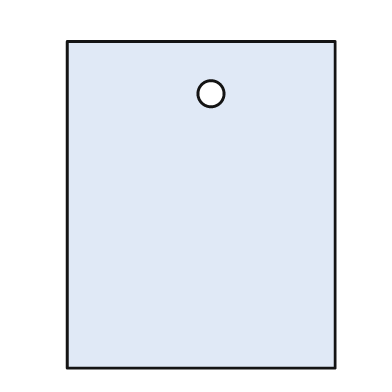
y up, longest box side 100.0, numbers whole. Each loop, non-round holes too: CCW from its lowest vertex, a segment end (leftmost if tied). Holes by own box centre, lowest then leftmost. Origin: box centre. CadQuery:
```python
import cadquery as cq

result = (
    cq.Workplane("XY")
    .moveTo(-41.0, -50.0)
    .lineTo(41.0, -50.0)
    .lineTo(41.0, 50.0)
    .lineTo(-41.0, 50.0)
    .close()
    .moveTo(3.0, 34.0)
    .circle(4.0)
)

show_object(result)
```